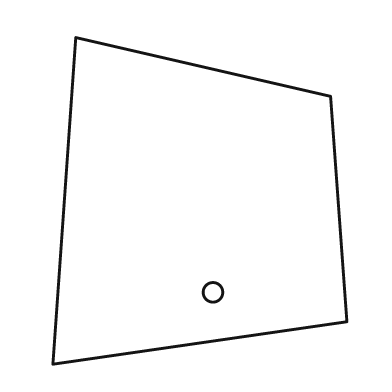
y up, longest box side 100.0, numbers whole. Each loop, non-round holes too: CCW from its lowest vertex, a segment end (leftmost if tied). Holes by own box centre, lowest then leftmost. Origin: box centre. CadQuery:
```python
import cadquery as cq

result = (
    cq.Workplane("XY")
    .moveTo(-45.0, -50.0)
    .lineTo(45.0, -37.0)
    .lineTo(40.0, 32.0)
    .lineTo(-38.0, 50.0)
    .close()
    .moveTo(4.0, -28.0)
    .circle(3.0)
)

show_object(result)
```